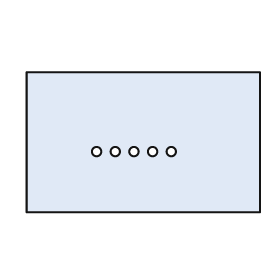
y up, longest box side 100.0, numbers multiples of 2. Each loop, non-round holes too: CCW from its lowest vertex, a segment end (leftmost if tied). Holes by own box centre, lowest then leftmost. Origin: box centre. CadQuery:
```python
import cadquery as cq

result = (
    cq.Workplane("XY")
    .moveTo(-50.0, -30.0)
    .lineTo(50.0, -30.0)
    .lineTo(50.0, 30.0)
    .lineTo(-50.0, 30.0)
    .close()
    .moveTo(-20.0, -4.0)
    .circle(2.0)
    .moveTo(-12.0, -4.0)
    .circle(2.0)
    .moveTo(-4.0, -4.0)
    .circle(2.0)
    .moveTo(4.0, -4.0)
    .circle(2.0)
    .moveTo(12.0, -4.0)
    .circle(2.0)
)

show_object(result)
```